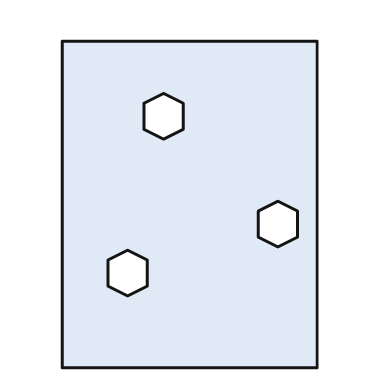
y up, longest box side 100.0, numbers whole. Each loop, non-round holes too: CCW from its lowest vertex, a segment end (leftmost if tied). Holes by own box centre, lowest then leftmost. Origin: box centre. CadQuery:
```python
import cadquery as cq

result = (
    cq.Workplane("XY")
    .moveTo(-39.0, -50.0)
    .lineTo(39.0, -50.0)
    .lineTo(39.0, 50.0)
    .lineTo(-39.0, 50.0)
    .close()
    .moveTo(-19.0, -28.0)
    .lineTo(-13.0, -25.0)
    .lineTo(-13.0, -17.0)
    .lineTo(-19.0, -14.0)
    .lineTo(-25.0, -17.0)
    .lineTo(-25.0, -25.0)
    .close()
    .moveTo(27.0, -13.0)
    .lineTo(33.0, -10.0)
    .lineTo(33.0, -2.0)
    .lineTo(27.0, 1.0)
    .lineTo(21.0, -2.0)
    .lineTo(21.0, -10.0)
    .close()
    .moveTo(-8.0, 20.0)
    .lineTo(-2.0, 23.0)
    .lineTo(-2.0, 31.0)
    .lineTo(-8.0, 34.0)
    .lineTo(-14.0, 31.0)
    .lineTo(-14.0, 23.0)
    .close()
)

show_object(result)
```